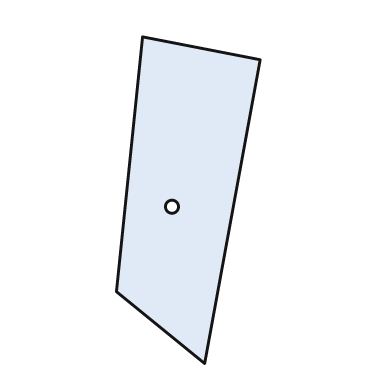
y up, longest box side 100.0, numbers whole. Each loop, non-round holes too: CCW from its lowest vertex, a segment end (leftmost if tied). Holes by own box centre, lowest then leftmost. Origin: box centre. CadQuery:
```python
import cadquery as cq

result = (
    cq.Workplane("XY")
    .moveTo(5.0, -50.0)
    .lineTo(22.0, 43.0)
    .lineTo(-14.0, 50.0)
    .lineTo(-22.0, -28.0)
    .close()
    .moveTo(-5.0, -2.0)
    .circle(2.0)
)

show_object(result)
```